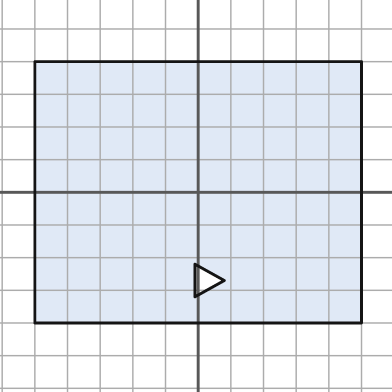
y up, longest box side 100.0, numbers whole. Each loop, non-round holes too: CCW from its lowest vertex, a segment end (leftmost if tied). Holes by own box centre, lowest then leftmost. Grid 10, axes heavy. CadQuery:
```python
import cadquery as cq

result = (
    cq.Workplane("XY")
    .moveTo(-50.0, -40.0)
    .lineTo(50.0, -40.0)
    .lineTo(50.0, 40.0)
    .lineTo(-50.0, 40.0)
    .close()
    .moveTo(-1.0, -32.0)
    .lineTo(8.0, -27.0)
    .lineTo(-1.0, -22.0)
    .close()
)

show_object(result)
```